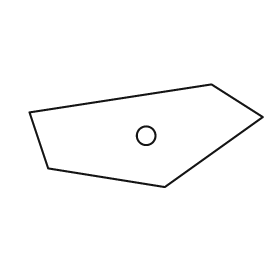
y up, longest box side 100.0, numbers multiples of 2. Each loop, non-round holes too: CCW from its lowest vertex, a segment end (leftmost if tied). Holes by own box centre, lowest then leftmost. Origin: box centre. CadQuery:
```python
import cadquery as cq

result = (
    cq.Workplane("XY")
    .moveTo(8.0, -22.0)
    .lineTo(50.0, 8.0)
    .lineTo(28.0, 22.0)
    .lineTo(-50.0, 10.0)
    .lineTo(-42.0, -14.0)
    .close()
    .moveTo(0.0, 0.0)
    .circle(4.0)
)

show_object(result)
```